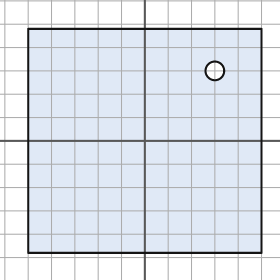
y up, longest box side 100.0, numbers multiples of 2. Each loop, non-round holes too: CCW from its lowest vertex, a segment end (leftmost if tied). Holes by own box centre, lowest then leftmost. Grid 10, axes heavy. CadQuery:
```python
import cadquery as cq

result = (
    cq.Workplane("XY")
    .moveTo(-50.0, -48.0)
    .lineTo(50.0, -48.0)
    .lineTo(50.0, 48.0)
    .lineTo(-50.0, 48.0)
    .close()
    .moveTo(30.0, 30.0)
    .circle(4.0)
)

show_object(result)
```